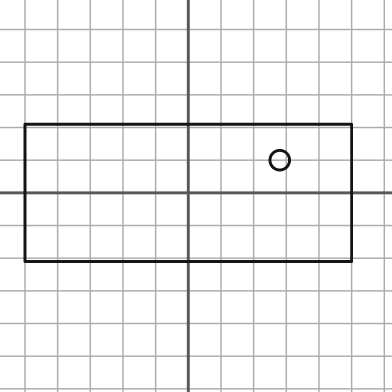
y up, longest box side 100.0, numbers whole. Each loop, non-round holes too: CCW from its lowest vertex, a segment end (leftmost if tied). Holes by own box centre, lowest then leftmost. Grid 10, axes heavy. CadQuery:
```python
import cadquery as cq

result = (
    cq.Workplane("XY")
    .moveTo(-50.0, -21.0)
    .lineTo(50.0, -21.0)
    .lineTo(50.0, 21.0)
    .lineTo(-50.0, 21.0)
    .close()
    .moveTo(28.0, 10.0)
    .circle(3.0)
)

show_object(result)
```